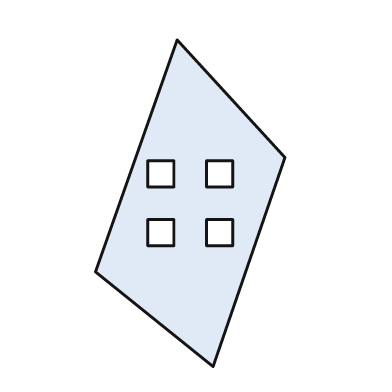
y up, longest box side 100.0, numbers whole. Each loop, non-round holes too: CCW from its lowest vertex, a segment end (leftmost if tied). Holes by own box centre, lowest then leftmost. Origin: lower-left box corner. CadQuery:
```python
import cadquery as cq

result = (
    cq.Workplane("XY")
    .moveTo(36.0, 0.0)
    .lineTo(58.0, 64.0)
    .lineTo(25.0, 100.0)
    .lineTo(0.0, 29.0)
    .close()
    .moveTo(16.0, 37.0)
    .lineTo(24.0, 37.0)
    .lineTo(24.0, 45.0)
    .lineTo(16.0, 45.0)
    .close()
    .moveTo(34.0, 37.0)
    .lineTo(42.0, 37.0)
    .lineTo(42.0, 45.0)
    .lineTo(34.0, 45.0)
    .close()
    .moveTo(16.0, 55.0)
    .lineTo(24.0, 55.0)
    .lineTo(24.0, 63.0)
    .lineTo(16.0, 63.0)
    .close()
    .moveTo(34.0, 55.0)
    .lineTo(42.0, 55.0)
    .lineTo(42.0, 63.0)
    .lineTo(34.0, 63.0)
    .close()
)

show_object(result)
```